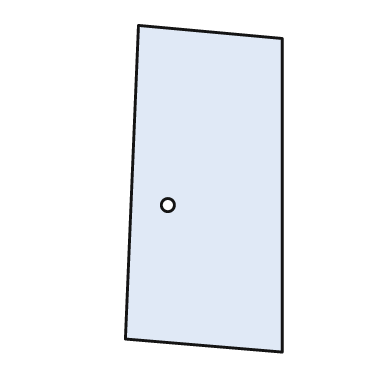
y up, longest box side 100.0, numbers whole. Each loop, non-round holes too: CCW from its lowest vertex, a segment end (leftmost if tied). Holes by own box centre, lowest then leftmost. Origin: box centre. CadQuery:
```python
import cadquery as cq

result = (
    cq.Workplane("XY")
    .moveTo(24.0, -50.0)
    .lineTo(24.0, 46.0)
    .lineTo(-20.0, 50.0)
    .lineTo(-24.0, -46.0)
    .close()
    .moveTo(-11.0, -5.0)
    .circle(2.0)
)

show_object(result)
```